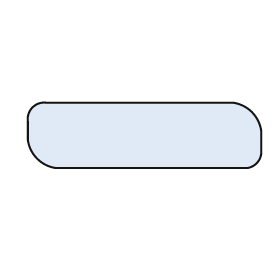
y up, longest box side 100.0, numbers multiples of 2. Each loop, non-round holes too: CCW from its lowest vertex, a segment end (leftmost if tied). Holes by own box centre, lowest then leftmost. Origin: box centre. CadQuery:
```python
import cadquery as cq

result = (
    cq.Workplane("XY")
    .moveTo(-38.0, -14.0)
    .lineTo(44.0, -14.0)
    .threePointArc((48.0, -12.0), (50.0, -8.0))
    .lineTo(50.0, 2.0)
    .threePointArc((46.0, 10.0), (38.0, 14.0))
    .lineTo(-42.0, 14.0)
    .threePointArc((-48.0, 12.0), (-50.0, 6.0))
    .lineTo(-50.0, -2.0)
    .threePointArc((-46.0, -10.0), (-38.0, -14.0))
    .close()
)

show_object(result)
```